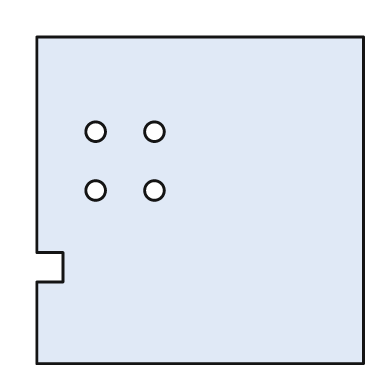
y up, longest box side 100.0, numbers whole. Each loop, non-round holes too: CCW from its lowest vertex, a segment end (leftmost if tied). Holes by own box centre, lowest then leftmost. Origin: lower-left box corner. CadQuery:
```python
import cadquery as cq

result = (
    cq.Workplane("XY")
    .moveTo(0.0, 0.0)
    .lineTo(100.0, 0.0)
    .lineTo(100.0, 100.0)
    .lineTo(0.0, 100.0)
    .lineTo(0.0, 34.0)
    .lineTo(8.0, 34.0)
    .lineTo(8.0, 25.0)
    .lineTo(0.0, 25.0)
    .close()
    .moveTo(18.0, 53.0)
    .circle(3.0)
    .moveTo(36.0, 53.0)
    .circle(3.0)
    .moveTo(18.0, 71.0)
    .circle(3.0)
    .moveTo(36.0, 71.0)
    .circle(3.0)
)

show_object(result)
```